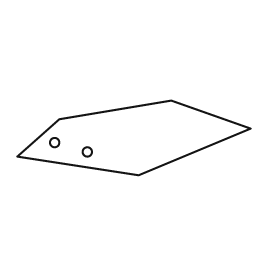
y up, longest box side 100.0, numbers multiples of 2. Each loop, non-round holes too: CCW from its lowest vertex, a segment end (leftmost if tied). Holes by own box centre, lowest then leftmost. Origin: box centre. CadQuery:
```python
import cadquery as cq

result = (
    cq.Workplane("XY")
    .moveTo(2.0, -16.0)
    .lineTo(50.0, 4.0)
    .lineTo(16.0, 16.0)
    .lineTo(-32.0, 8.0)
    .lineTo(-50.0, -8.0)
    .close()
    .moveTo(-20.0, -6.0)
    .circle(2.0)
    .moveTo(-34.0, -2.0)
    .circle(2.0)
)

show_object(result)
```